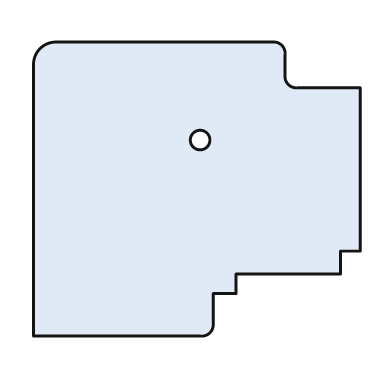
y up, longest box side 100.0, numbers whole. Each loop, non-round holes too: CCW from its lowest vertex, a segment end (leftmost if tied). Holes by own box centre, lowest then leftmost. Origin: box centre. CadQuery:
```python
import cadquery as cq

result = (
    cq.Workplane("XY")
    .moveTo(-50.0, -45.0)
    .lineTo(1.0, -45.0)
    .threePointArc((4.0, -44.0), (5.0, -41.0))
    .lineTo(5.0, -32.0)
    .lineTo(12.0, -32.0)
    .lineTo(12.0, -26.0)
    .lineTo(44.0, -26.0)
    .lineTo(44.0, -19.0)
    .lineTo(50.0, -19.0)
    .lineTo(50.0, 31.0)
    .lineTo(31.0, 31.0)
    .threePointArc((28.0, 32.0), (27.0, 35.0))
    .lineTo(27.0, 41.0)
    .threePointArc((26.0, 44.0), (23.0, 45.0))
    .lineTo(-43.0, 45.0)
    .threePointArc((-48.0, 43.0), (-50.0, 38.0))
    .close()
    .moveTo(1.0, 15.0)
    .circle(3.0)
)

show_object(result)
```